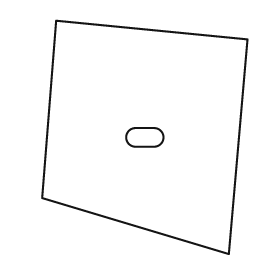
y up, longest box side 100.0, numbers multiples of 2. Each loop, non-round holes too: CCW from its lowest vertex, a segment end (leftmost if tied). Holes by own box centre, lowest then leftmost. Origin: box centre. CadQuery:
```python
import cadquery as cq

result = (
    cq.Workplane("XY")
    .moveTo(36.0, -50.0)
    .lineTo(44.0, 42.0)
    .lineTo(-38.0, 50.0)
    .lineTo(-44.0, -26.0)
    .close()
    .moveTo(-4.0, -4.0)
    .lineTo(4.0, -4.0)
    .threePointArc((8.0, 0.0), (4.0, 4.0))
    .lineTo(-4.0, 4.0)
    .threePointArc((-8.0, 0.0), (-4.0, -4.0))
    .close()
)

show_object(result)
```